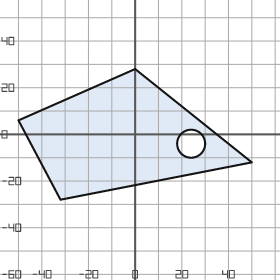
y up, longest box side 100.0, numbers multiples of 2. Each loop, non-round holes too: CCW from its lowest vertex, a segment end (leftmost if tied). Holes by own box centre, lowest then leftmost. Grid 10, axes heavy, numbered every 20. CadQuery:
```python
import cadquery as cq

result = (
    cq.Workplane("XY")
    .moveTo(-32.0, -28.0)
    .lineTo(50.0, -12.0)
    .lineTo(0.0, 28.0)
    .lineTo(-50.0, 6.0)
    .close()
    .moveTo(24.0, -4.0)
    .circle(6.0)
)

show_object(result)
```